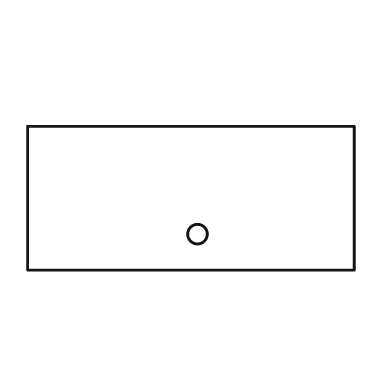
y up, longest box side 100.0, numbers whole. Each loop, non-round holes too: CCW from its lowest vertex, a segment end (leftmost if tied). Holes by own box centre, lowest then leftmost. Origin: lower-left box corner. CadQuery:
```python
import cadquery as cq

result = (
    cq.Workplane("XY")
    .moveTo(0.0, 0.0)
    .lineTo(100.0, 0.0)
    .lineTo(100.0, 44.0)
    .lineTo(0.0, 44.0)
    .close()
    .moveTo(52.0, 11.0)
    .circle(3.0)
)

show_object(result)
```